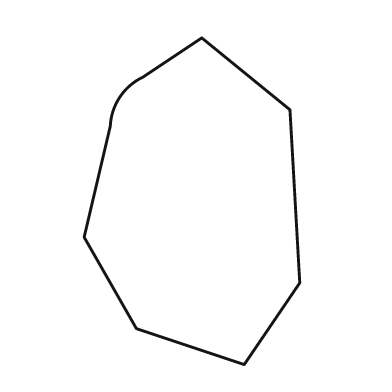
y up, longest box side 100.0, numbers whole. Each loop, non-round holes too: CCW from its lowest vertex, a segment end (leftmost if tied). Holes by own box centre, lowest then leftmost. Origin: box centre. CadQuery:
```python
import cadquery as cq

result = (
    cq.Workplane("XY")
    .moveTo(16.0, -50.0)
    .lineTo(33.0, -25.0)
    .lineTo(30.0, 28.0)
    .lineTo(3.0, 50.0)
    .lineTo(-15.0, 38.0)
    .threePointArc((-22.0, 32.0), (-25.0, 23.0))
    .lineTo(-33.0, -11.0)
    .lineTo(-17.0, -39.0)
    .close()
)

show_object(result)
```